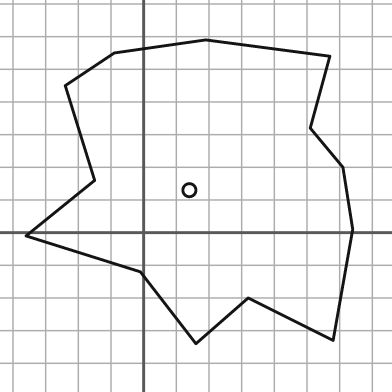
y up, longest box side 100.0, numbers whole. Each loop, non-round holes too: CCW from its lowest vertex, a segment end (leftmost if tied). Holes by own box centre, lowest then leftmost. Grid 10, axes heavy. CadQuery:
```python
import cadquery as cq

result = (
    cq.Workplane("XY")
    .moveTo(16.0, -34.0)
    .lineTo(32.0, -20.0)
    .lineTo(58.0, -33.0)
    .lineTo(64.0, 1.0)
    .lineTo(61.0, 20.0)
    .lineTo(51.0, 32.0)
    .lineTo(57.0, 54.0)
    .lineTo(19.0, 59.0)
    .lineTo(-9.0, 55.0)
    .lineTo(-24.0, 45.0)
    .lineTo(-15.0, 16.0)
    .lineTo(-36.0, -1.0)
    .lineTo(-1.0, -12.0)
    .close()
    .moveTo(14.0, 13.0)
    .circle(2.0)
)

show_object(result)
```